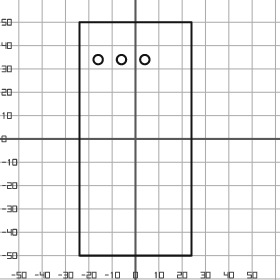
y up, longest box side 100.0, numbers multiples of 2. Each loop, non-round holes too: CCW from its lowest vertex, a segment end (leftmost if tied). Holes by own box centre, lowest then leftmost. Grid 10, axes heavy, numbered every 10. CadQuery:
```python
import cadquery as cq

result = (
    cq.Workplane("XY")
    .moveTo(-24.0, -50.0)
    .lineTo(24.0, -50.0)
    .lineTo(24.0, 50.0)
    .lineTo(-24.0, 50.0)
    .close()
    .moveTo(-16.0, 34.0)
    .circle(2.0)
    .moveTo(-6.0, 34.0)
    .circle(2.0)
    .moveTo(4.0, 34.0)
    .circle(2.0)
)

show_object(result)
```